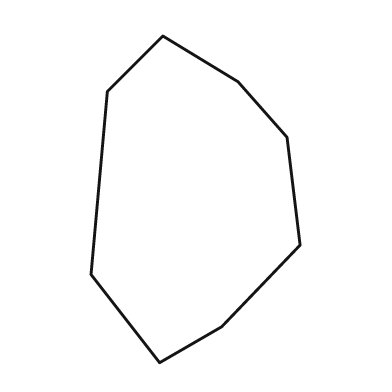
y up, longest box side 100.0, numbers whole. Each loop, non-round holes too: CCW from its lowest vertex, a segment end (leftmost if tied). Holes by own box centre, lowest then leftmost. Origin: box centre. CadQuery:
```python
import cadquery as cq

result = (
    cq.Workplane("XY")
    .moveTo(-11.0, -50.0)
    .lineTo(8.0, -39.0)
    .lineTo(32.0, -14.0)
    .lineTo(28.0, 19.0)
    .lineTo(13.0, 36.0)
    .lineTo(-10.0, 50.0)
    .lineTo(-27.0, 33.0)
    .lineTo(-32.0, -23.0)
    .close()
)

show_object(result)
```